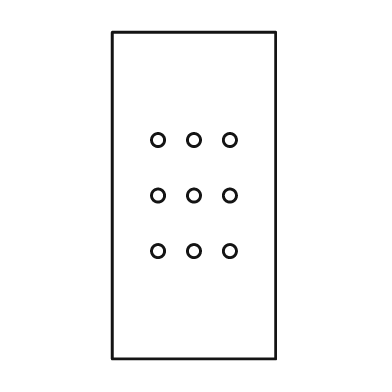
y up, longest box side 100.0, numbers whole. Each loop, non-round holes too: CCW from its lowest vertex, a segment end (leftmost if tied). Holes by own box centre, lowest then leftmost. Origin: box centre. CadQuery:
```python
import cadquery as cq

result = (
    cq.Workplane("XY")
    .moveTo(-25.0, -50.0)
    .lineTo(25.0, -50.0)
    .lineTo(25.0, 50.0)
    .lineTo(-25.0, 50.0)
    .close()
    .moveTo(-11.0, -17.0)
    .circle(2.0)
    .moveTo(0.0, -17.0)
    .circle(2.0)
    .moveTo(11.0, -17.0)
    .circle(2.0)
    .moveTo(-11.0, 0.0)
    .circle(2.0)
    .moveTo(0.0, 0.0)
    .circle(2.0)
    .moveTo(11.0, 0.0)
    .circle(2.0)
    .moveTo(-11.0, 17.0)
    .circle(2.0)
    .moveTo(0.0, 17.0)
    .circle(2.0)
    .moveTo(11.0, 17.0)
    .circle(2.0)
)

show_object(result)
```